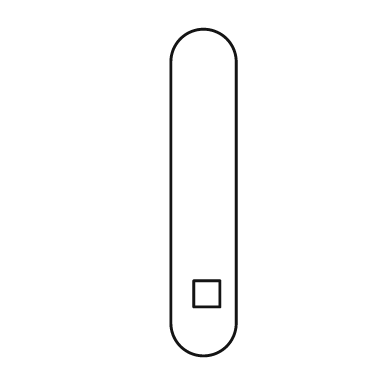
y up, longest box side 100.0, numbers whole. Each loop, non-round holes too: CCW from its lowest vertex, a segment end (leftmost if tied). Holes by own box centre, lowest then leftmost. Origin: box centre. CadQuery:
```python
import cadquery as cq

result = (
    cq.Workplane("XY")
    .moveTo(-10.0, -40.0)
    .threePointArc((0.0, -50.0), (10.0, -40.0))
    .lineTo(10.0, 40.0)
    .threePointArc((0.0, 50.0), (-10.0, 40.0))
    .close()
    .moveTo(-3.0, -35.0)
    .lineTo(5.0, -35.0)
    .lineTo(5.0, -27.0)
    .lineTo(-3.0, -27.0)
    .close()
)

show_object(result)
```